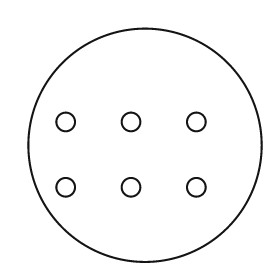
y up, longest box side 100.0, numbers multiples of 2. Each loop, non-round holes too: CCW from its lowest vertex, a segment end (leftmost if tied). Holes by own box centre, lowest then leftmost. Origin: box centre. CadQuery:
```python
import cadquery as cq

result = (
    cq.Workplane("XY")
    .moveTo(0.0, 0.0)
    .circle(50.0)
    .moveTo(-34.0, -18.0)
    .circle(4.0)
    .moveTo(-6.0, -18.0)
    .circle(4.0)
    .moveTo(22.0, -18.0)
    .circle(4.0)
    .moveTo(-34.0, 10.0)
    .circle(4.0)
    .moveTo(-6.0, 10.0)
    .circle(4.0)
    .moveTo(22.0, 10.0)
    .circle(4.0)
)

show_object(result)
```